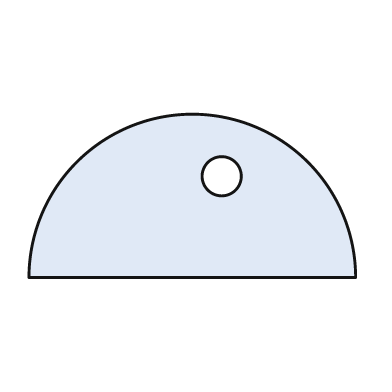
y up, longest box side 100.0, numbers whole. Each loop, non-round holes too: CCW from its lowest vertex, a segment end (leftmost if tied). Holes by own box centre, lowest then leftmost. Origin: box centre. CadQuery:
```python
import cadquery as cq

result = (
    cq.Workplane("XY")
    .moveTo(-50.0, -25.0)
    .lineTo(50.0, -25.0)
    .threePointArc((0.0, 25.0), (-50.0, -25.0))
    .close()
    .moveTo(9.0, 6.0)
    .circle(6.0)
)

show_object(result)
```